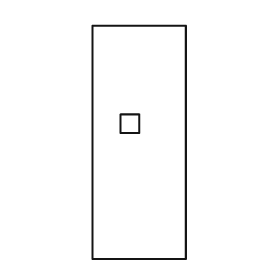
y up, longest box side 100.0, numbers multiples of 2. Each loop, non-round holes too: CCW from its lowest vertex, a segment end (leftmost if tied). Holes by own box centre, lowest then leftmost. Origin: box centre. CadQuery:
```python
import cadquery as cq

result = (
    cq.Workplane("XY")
    .moveTo(-20.0, -50.0)
    .lineTo(20.0, -50.0)
    .lineTo(20.0, 50.0)
    .lineTo(-20.0, 50.0)
    .close()
    .moveTo(-8.0, 4.0)
    .lineTo(0.0, 4.0)
    .lineTo(0.0, 12.0)
    .lineTo(-8.0, 12.0)
    .close()
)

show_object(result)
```